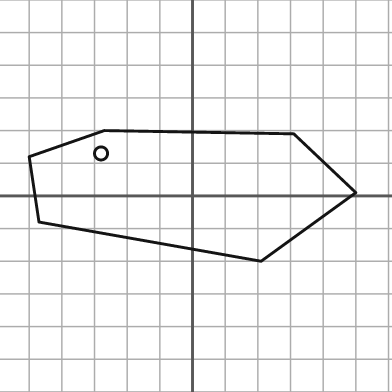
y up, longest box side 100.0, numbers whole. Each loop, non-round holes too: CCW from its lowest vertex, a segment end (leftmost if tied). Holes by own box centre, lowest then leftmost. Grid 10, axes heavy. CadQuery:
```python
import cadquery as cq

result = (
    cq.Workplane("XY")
    .moveTo(21.0, -20.0)
    .lineTo(50.0, 1.0)
    .lineTo(31.0, 19.0)
    .lineTo(-27.0, 20.0)
    .lineTo(-50.0, 12.0)
    .lineTo(-47.0, -8.0)
    .close()
    .moveTo(-28.0, 13.0)
    .circle(2.0)
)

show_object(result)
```